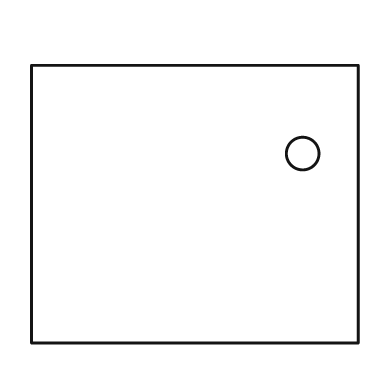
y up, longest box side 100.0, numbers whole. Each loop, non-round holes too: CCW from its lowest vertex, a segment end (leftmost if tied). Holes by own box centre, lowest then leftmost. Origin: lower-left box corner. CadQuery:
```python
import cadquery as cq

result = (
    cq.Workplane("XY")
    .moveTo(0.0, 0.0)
    .lineTo(100.0, 0.0)
    .lineTo(100.0, 85.0)
    .lineTo(0.0, 85.0)
    .close()
    .moveTo(83.0, 58.0)
    .circle(5.0)
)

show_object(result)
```